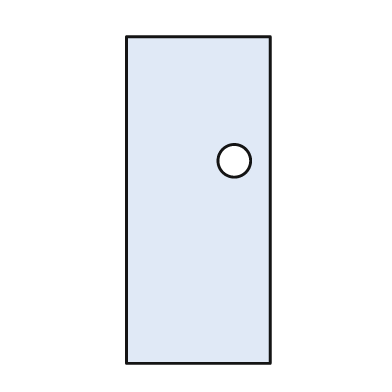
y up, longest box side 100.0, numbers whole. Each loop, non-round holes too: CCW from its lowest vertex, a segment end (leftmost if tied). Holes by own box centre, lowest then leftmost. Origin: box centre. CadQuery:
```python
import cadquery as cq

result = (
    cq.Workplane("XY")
    .moveTo(-22.0, -50.0)
    .lineTo(22.0, -50.0)
    .lineTo(22.0, 50.0)
    .lineTo(-22.0, 50.0)
    .close()
    .moveTo(11.0, 12.0)
    .circle(5.0)
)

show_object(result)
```